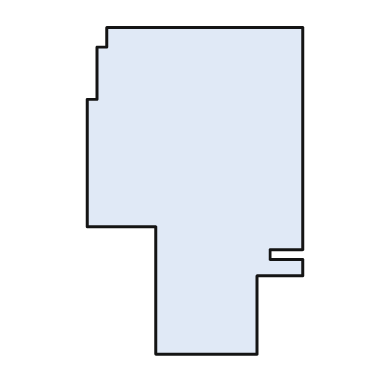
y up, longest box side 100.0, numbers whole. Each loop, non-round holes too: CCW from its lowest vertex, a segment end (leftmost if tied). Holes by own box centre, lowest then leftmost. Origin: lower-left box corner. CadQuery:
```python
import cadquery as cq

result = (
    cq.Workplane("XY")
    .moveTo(21.0, 0.0)
    .lineTo(52.0, 0.0)
    .lineTo(52.0, 24.0)
    .lineTo(66.0, 24.0)
    .lineTo(66.0, 29.0)
    .lineTo(56.0, 29.0)
    .lineTo(56.0, 32.0)
    .lineTo(66.0, 32.0)
    .lineTo(66.0, 100.0)
    .lineTo(6.0, 100.0)
    .lineTo(6.0, 94.0)
    .lineTo(3.0, 94.0)
    .lineTo(3.0, 78.0)
    .lineTo(0.0, 78.0)
    .lineTo(0.0, 39.0)
    .lineTo(21.0, 39.0)
    .close()
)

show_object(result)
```